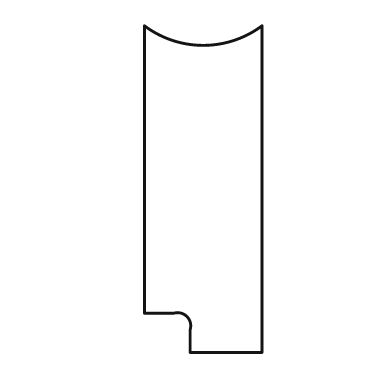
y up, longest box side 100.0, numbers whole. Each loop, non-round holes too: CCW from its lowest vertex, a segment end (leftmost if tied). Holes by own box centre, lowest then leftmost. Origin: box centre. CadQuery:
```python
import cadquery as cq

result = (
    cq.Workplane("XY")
    .moveTo(-4.0, -50.0)
    .lineTo(18.0, -50.0)
    .lineTo(18.0, 50.0)
    .threePointArc((0.0, 44.0), (-18.0, 50.0))
    .lineTo(-18.0, -38.0)
    .lineTo(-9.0, -38.0)
    .threePointArc((-5.0, -39.0), (-4.0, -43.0))
    .close()
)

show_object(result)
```